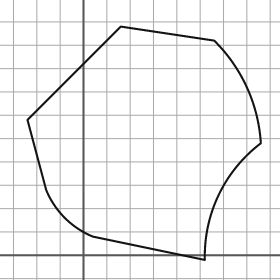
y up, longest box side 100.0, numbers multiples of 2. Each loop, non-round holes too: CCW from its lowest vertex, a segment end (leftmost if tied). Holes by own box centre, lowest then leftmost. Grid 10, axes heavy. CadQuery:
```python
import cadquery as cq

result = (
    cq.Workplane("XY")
    .moveTo(52.0, -2.0)
    .threePointArc((58.0, 26.0), (76.0, 48.0))
    .threePointArc((70.0, 72.0), (56.0, 92.0))
    .lineTo(16.0, 98.0)
    .lineTo(-24.0, 58.0)
    .lineTo(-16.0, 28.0)
    .threePointArc((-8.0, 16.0), (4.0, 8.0))
    .close()
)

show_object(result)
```